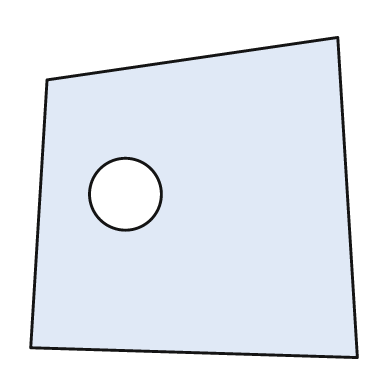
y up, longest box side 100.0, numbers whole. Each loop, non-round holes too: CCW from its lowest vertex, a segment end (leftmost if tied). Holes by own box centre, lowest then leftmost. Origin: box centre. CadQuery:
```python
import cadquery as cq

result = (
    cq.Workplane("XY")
    .moveTo(50.0, -49.0)
    .lineTo(44.0, 49.0)
    .lineTo(-45.0, 36.0)
    .lineTo(-50.0, -46.0)
    .close()
    .moveTo(-21.0, 1.0)
    .circle(11.0)
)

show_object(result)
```